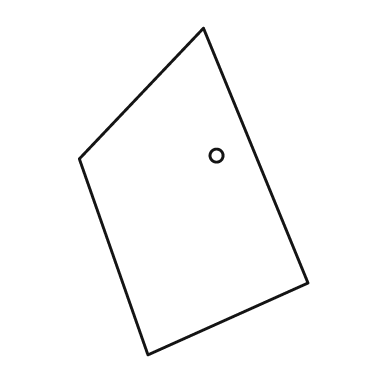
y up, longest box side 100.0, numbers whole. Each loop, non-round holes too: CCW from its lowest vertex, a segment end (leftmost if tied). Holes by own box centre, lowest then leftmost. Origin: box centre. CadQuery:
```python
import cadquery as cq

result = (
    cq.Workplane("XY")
    .moveTo(-14.0, -50.0)
    .lineTo(35.0, -28.0)
    .lineTo(3.0, 50.0)
    .lineTo(-35.0, 10.0)
    .close()
    .moveTo(7.0, 11.0)
    .circle(2.0)
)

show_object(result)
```